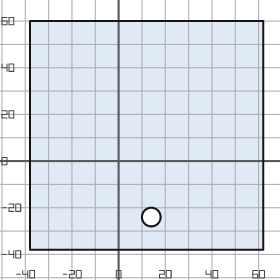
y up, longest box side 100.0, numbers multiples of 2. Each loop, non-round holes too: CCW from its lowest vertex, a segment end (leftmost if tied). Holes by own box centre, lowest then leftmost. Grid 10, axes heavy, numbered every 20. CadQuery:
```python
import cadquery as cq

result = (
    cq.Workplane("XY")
    .moveTo(-38.0, -38.0)
    .lineTo(62.0, -38.0)
    .lineTo(62.0, 60.0)
    .lineTo(-38.0, 60.0)
    .close()
    .moveTo(14.0, -24.0)
    .circle(4.0)
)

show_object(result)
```